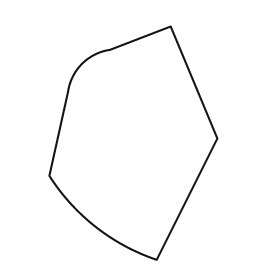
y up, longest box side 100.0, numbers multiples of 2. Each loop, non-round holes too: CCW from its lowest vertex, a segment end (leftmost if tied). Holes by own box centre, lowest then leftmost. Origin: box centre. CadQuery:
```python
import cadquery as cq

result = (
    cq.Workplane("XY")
    .moveTo(10.0, -50.0)
    .lineTo(36.0, 2.0)
    .lineTo(16.0, 50.0)
    .lineTo(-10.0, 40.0)
    .threePointArc((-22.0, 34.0), (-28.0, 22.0))
    .lineTo(-36.0, -14.0)
    .threePointArc((-16.0, -36.0), (10.0, -50.0))
    .close()
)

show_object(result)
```